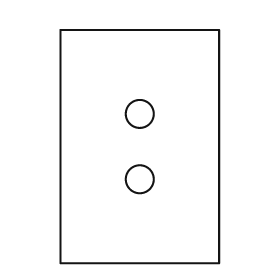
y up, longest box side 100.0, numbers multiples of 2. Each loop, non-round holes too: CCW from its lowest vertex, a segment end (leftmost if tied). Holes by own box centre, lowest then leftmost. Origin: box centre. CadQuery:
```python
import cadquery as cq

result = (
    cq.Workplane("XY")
    .moveTo(-34.0, -50.0)
    .lineTo(34.0, -50.0)
    .lineTo(34.0, 50.0)
    .lineTo(-34.0, 50.0)
    .close()
    .moveTo(0.0, -14.0)
    .circle(6.0)
    .moveTo(0.0, 14.0)
    .circle(6.0)
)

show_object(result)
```